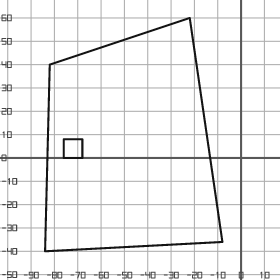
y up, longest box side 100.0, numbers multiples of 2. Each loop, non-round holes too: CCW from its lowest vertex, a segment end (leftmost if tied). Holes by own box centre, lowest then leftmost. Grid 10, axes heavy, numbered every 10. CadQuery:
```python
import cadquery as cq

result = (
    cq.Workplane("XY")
    .moveTo(-84.0, -40.0)
    .lineTo(-8.0, -36.0)
    .lineTo(-22.0, 60.0)
    .lineTo(-82.0, 40.0)
    .close()
    .moveTo(-76.0, 0.0)
    .lineTo(-68.0, 0.0)
    .lineTo(-68.0, 8.0)
    .lineTo(-76.0, 8.0)
    .close()
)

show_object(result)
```